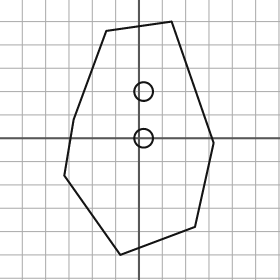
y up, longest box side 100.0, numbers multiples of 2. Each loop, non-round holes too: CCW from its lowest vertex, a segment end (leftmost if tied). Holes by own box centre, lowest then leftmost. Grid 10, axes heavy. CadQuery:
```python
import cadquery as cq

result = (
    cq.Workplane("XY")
    .moveTo(-8.0, -50.0)
    .lineTo(24.0, -38.0)
    .lineTo(32.0, -2.0)
    .lineTo(14.0, 50.0)
    .lineTo(-14.0, 46.0)
    .lineTo(-28.0, 8.0)
    .lineTo(-32.0, -16.0)
    .close()
    .moveTo(2.0, 0.0)
    .circle(4.0)
    .moveTo(2.0, 20.0)
    .circle(4.0)
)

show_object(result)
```